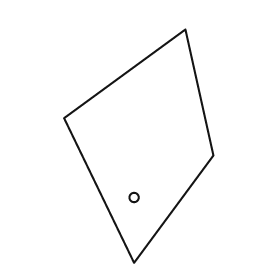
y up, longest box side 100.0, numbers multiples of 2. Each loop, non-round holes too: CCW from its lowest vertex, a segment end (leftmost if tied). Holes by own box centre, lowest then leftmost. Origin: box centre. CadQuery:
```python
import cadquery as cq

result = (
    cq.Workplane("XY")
    .moveTo(-2.0, -50.0)
    .lineTo(32.0, -4.0)
    .lineTo(20.0, 50.0)
    .lineTo(-32.0, 12.0)
    .close()
    .moveTo(-2.0, -22.0)
    .circle(2.0)
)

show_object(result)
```